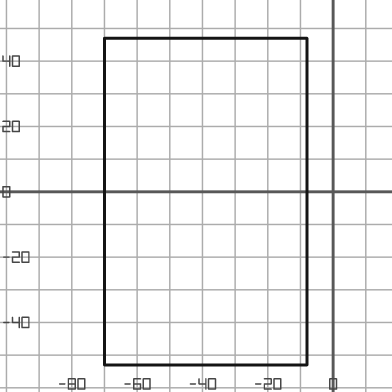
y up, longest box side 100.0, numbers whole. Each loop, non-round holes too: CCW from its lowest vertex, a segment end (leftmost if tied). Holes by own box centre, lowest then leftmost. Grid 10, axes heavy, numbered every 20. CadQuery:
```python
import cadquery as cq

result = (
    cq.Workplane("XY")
    .moveTo(-70.0, -53.0)
    .lineTo(-8.0, -53.0)
    .lineTo(-8.0, 47.0)
    .lineTo(-70.0, 47.0)
    .close()
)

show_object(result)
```